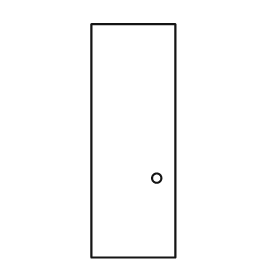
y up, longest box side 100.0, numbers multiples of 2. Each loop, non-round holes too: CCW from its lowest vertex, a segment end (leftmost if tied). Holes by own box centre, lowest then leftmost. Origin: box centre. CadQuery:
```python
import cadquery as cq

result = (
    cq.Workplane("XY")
    .moveTo(-18.0, -50.0)
    .lineTo(18.0, -50.0)
    .lineTo(18.0, 50.0)
    .lineTo(-18.0, 50.0)
    .close()
    .moveTo(10.0, -16.0)
    .circle(2.0)
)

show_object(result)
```